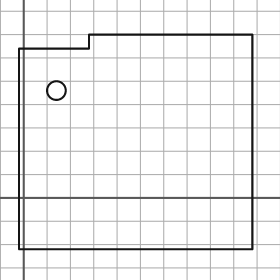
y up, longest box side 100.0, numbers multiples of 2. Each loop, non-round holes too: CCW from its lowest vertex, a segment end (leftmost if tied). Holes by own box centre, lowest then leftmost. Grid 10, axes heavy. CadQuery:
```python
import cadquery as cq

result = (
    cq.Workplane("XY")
    .moveTo(-2.0, -22.0)
    .lineTo(98.0, -22.0)
    .lineTo(98.0, 70.0)
    .lineTo(28.0, 70.0)
    .lineTo(28.0, 64.0)
    .lineTo(-2.0, 64.0)
    .close()
    .moveTo(14.0, 46.0)
    .circle(4.0)
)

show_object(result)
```